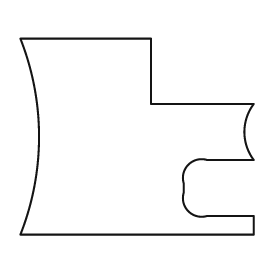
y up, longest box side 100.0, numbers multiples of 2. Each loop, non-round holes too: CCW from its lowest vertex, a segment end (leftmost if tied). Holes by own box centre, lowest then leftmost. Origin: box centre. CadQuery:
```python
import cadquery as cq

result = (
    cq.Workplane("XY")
    .moveTo(-50.0, -42.0)
    .lineTo(50.0, -42.0)
    .lineTo(50.0, -34.0)
    .lineTo(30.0, -34.0)
    .threePointArc((22.0, -32.0), (20.0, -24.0))
    .lineTo(20.0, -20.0)
    .threePointArc((22.0, -12.0), (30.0, -10.0))
    .lineTo(50.0, -10.0)
    .threePointArc((46.0, 2.0), (50.0, 14.0))
    .lineTo(6.0, 14.0)
    .lineTo(6.0, 42.0)
    .lineTo(-50.0, 42.0)
    .threePointArc((-42.0, 0.0), (-50.0, -42.0))
    .close()
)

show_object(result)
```